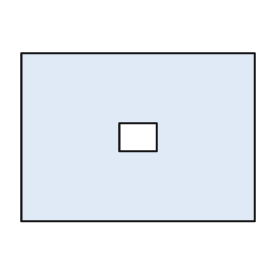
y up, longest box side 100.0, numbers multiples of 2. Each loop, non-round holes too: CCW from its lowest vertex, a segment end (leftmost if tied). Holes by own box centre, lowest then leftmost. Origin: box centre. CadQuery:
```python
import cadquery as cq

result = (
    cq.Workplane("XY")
    .moveTo(-50.0, -36.0)
    .lineTo(50.0, -36.0)
    .lineTo(50.0, 36.0)
    .lineTo(-50.0, 36.0)
    .close()
    .moveTo(-8.0, -6.0)
    .lineTo(8.0, -6.0)
    .lineTo(8.0, 6.0)
    .lineTo(-8.0, 6.0)
    .close()
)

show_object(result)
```